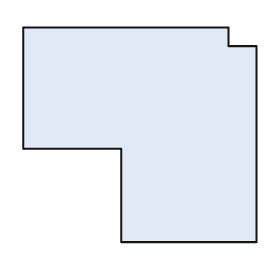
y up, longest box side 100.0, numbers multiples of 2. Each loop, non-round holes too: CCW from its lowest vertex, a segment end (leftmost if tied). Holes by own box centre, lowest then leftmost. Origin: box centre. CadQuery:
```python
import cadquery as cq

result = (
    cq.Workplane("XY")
    .moveTo(-8.0, -46.0)
    .lineTo(50.0, -46.0)
    .lineTo(50.0, 38.0)
    .lineTo(38.0, 38.0)
    .lineTo(38.0, 46.0)
    .lineTo(-50.0, 46.0)
    .lineTo(-50.0, -6.0)
    .lineTo(-8.0, -6.0)
    .close()
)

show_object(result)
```